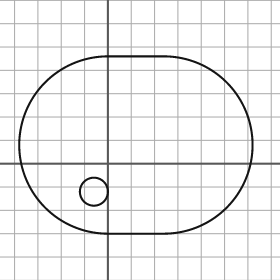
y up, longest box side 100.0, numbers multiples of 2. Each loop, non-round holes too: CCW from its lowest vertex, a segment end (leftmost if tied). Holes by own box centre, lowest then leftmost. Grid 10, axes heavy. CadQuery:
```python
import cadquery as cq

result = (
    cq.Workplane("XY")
    .moveTo(0.0, -30.0)
    .lineTo(24.0, -30.0)
    .threePointArc((62.0, 8.0), (24.0, 46.0))
    .lineTo(0.0, 46.0)
    .threePointArc((-38.0, 8.0), (0.0, -30.0))
    .close()
    .moveTo(-6.0, -12.0)
    .circle(6.0)
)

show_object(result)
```